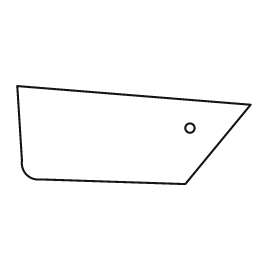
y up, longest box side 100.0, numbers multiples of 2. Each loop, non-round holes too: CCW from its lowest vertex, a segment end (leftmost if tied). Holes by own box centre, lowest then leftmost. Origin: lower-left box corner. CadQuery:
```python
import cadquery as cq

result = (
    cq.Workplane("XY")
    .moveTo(72.0, 0.0)
    .lineTo(100.0, 34.0)
    .lineTo(0.0, 42.0)
    .lineTo(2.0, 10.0)
    .threePointArc((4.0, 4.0), (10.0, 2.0))
    .close()
    .moveTo(74.0, 24.0)
    .circle(2.0)
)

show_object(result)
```